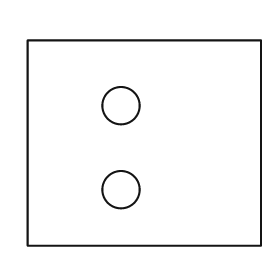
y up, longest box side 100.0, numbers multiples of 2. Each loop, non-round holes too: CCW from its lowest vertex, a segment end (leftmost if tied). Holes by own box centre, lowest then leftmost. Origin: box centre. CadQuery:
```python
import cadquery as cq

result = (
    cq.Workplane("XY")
    .moveTo(-50.0, -44.0)
    .lineTo(50.0, -44.0)
    .lineTo(50.0, 44.0)
    .lineTo(-50.0, 44.0)
    .close()
    .moveTo(-10.0, -20.0)
    .circle(8.0)
    .moveTo(-10.0, 16.0)
    .circle(8.0)
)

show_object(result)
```